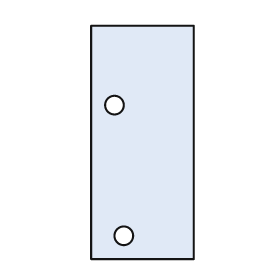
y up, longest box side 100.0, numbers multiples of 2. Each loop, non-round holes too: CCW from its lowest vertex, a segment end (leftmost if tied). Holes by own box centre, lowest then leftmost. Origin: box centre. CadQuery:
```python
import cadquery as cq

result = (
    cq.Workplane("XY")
    .moveTo(-22.0, -50.0)
    .lineTo(22.0, -50.0)
    .lineTo(22.0, 50.0)
    .lineTo(-22.0, 50.0)
    .close()
    .moveTo(-8.0, -40.0)
    .circle(4.0)
    .moveTo(-12.0, 16.0)
    .circle(4.0)
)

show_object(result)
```